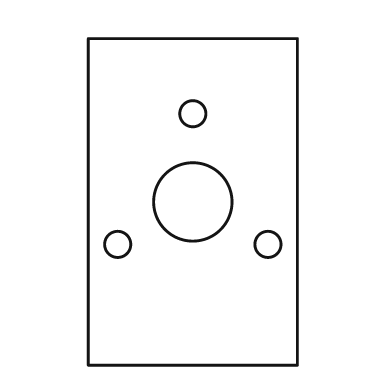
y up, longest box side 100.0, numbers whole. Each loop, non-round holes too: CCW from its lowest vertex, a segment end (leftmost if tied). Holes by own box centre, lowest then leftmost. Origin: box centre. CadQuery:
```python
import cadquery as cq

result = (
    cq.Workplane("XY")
    .moveTo(-32.0, -50.0)
    .lineTo(32.0, -50.0)
    .lineTo(32.0, 50.0)
    .lineTo(-32.0, 50.0)
    .close()
    .moveTo(-23.0, -13.0)
    .circle(4.0)
    .moveTo(23.0, -13.0)
    .circle(4.0)
    .moveTo(0.0, 0.0)
    .circle(12.0)
    .moveTo(0.0, 27.0)
    .circle(4.0)
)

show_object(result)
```